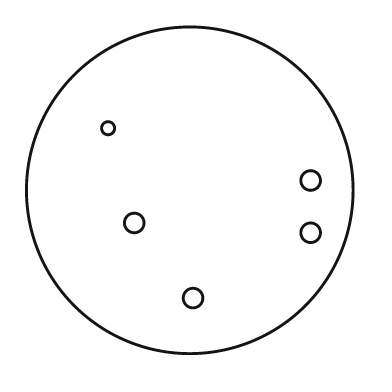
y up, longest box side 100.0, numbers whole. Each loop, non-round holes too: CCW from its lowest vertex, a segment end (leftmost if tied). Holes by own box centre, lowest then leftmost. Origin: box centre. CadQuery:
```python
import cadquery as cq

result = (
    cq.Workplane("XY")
    .moveTo(0.0, 0.0)
    .circle(50.0)
    .moveTo(1.0, -33.0)
    .circle(3.0)
    .moveTo(37.0, -13.0)
    .circle(3.0)
    .moveTo(-17.0, -10.0)
    .circle(3.0)
    .moveTo(37.0, 3.0)
    .circle(3.0)
    .moveTo(-25.0, 19.0)
    .circle(2.0)
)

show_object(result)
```